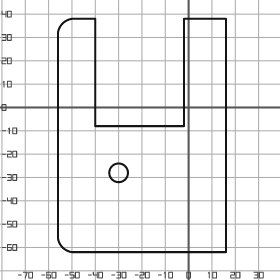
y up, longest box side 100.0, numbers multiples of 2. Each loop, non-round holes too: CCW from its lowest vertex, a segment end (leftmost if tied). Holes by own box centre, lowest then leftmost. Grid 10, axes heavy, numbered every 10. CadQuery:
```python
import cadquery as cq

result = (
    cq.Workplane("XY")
    .moveTo(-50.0, -62.0)
    .lineTo(16.0, -62.0)
    .lineTo(16.0, 38.0)
    .lineTo(-2.0, 38.0)
    .lineTo(-2.0, -8.0)
    .lineTo(-40.0, -8.0)
    .lineTo(-40.0, 38.0)
    .lineTo(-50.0, 38.0)
    .threePointArc((-54.0, 36.0), (-56.0, 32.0))
    .lineTo(-56.0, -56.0)
    .threePointArc((-54.0, -60.0), (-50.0, -62.0))
    .close()
    .moveTo(-30.0, -28.0)
    .circle(4.0)
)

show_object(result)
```